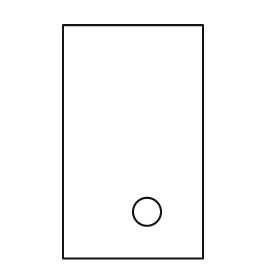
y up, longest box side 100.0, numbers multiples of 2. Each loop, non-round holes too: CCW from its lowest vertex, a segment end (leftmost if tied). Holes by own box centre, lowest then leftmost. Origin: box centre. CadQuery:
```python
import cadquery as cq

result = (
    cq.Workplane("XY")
    .moveTo(-30.0, -50.0)
    .lineTo(30.0, -50.0)
    .lineTo(30.0, 50.0)
    .lineTo(-30.0, 50.0)
    .close()
    .moveTo(6.0, -30.0)
    .circle(6.0)
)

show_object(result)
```